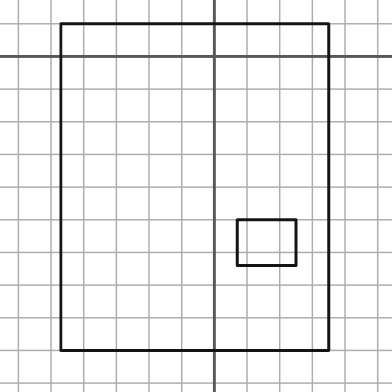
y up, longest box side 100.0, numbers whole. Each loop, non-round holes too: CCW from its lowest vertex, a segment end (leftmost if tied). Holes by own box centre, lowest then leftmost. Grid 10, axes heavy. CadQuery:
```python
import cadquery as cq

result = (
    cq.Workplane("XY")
    .moveTo(-47.0, -90.0)
    .lineTo(35.0, -90.0)
    .lineTo(35.0, 10.0)
    .lineTo(-47.0, 10.0)
    .close()
    .moveTo(7.0, -64.0)
    .lineTo(25.0, -64.0)
    .lineTo(25.0, -50.0)
    .lineTo(7.0, -50.0)
    .close()
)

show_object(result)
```